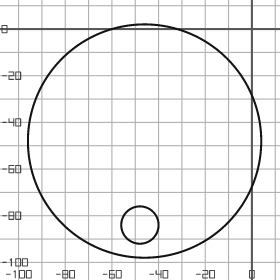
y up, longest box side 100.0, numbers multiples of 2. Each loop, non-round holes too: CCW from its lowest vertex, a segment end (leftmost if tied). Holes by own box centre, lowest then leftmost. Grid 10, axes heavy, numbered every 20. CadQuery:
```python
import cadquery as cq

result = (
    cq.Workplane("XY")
    .moveTo(-46.0, -48.0)
    .circle(50.0)
    .moveTo(-48.0, -84.0)
    .circle(8.0)
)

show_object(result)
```